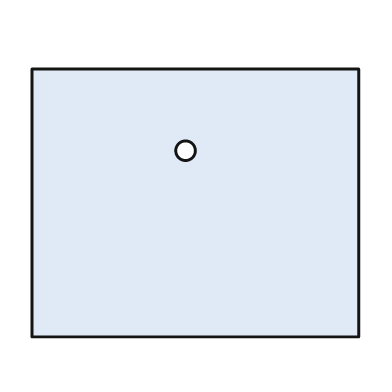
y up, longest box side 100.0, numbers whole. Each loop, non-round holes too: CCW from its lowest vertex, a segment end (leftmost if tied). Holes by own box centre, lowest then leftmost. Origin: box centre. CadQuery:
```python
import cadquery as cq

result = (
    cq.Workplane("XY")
    .moveTo(-50.0, -41.0)
    .lineTo(50.0, -41.0)
    .lineTo(50.0, 41.0)
    .lineTo(-50.0, 41.0)
    .close()
    .moveTo(-3.0, 16.0)
    .circle(3.0)
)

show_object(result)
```